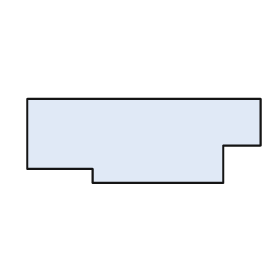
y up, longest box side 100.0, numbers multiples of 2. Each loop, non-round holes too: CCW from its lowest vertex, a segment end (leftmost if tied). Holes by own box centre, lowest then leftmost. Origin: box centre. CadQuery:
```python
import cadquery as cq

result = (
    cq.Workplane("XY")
    .moveTo(-22.0, -18.0)
    .lineTo(34.0, -18.0)
    .lineTo(34.0, -2.0)
    .lineTo(50.0, -2.0)
    .lineTo(50.0, 18.0)
    .lineTo(-50.0, 18.0)
    .lineTo(-50.0, -12.0)
    .lineTo(-22.0, -12.0)
    .close()
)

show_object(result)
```